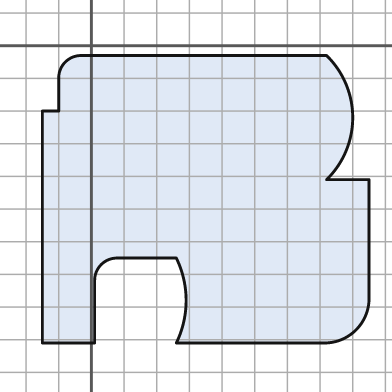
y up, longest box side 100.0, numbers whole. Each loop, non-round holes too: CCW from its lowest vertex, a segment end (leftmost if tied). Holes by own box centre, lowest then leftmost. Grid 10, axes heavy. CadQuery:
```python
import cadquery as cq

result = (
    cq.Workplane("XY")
    .moveTo(-15.0, -91.0)
    .lineTo(1.0, -91.0)
    .lineTo(1.0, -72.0)
    .threePointArc((3.0, -67.0), (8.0, -65.0))
    .lineTo(26.0, -65.0)
    .threePointArc((29.0, -78.0), (26.0, -91.0))
    .lineTo(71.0, -91.0)
    .threePointArc((81.0, -87.0), (85.0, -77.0))
    .lineTo(85.0, -41.0)
    .lineTo(72.0, -41.0)
    .threePointArc((80.0, -22.0), (72.0, -3.0))
    .lineTo(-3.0, -3.0)
    .threePointArc((-8.0, -5.0), (-10.0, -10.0))
    .lineTo(-10.0, -20.0)
    .lineTo(-15.0, -20.0)
    .close()
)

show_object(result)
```